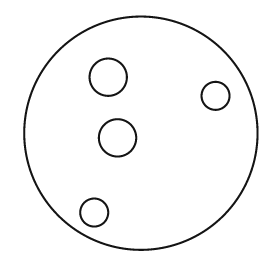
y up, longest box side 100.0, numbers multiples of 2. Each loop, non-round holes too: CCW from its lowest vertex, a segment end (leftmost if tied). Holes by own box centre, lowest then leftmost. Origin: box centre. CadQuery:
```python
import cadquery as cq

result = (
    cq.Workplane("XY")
    .moveTo(0.0, 0.0)
    .circle(50.0)
    .moveTo(-20.0, -34.0)
    .circle(6.0)
    .moveTo(-10.0, -2.0)
    .circle(8.0)
    .moveTo(32.0, 16.0)
    .circle(6.0)
    .moveTo(-14.0, 24.0)
    .circle(8.0)
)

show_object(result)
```